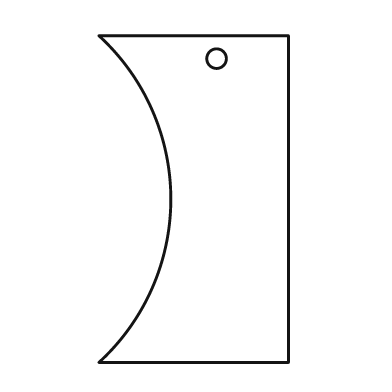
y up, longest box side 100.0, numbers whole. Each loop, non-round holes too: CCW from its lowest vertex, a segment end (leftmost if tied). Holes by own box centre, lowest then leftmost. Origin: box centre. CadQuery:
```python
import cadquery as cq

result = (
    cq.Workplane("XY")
    .moveTo(-29.0, -50.0)
    .lineTo(29.0, -50.0)
    .lineTo(29.0, 50.0)
    .lineTo(-29.0, 50.0)
    .threePointArc((-7.0, 0.0), (-29.0, -50.0))
    .close()
    .moveTo(7.0, 43.0)
    .circle(3.0)
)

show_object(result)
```